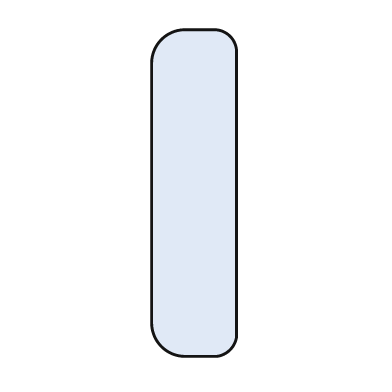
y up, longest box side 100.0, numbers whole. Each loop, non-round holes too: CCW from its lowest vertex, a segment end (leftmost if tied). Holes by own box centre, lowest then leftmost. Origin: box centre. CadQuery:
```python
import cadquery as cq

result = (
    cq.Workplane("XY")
    .moveTo(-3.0, -50.0)
    .lineTo(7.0, -50.0)
    .threePointArc((11.0, -48.0), (13.0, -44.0))
    .lineTo(13.0, 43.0)
    .threePointArc((11.0, 48.0), (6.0, 50.0))
    .lineTo(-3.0, 50.0)
    .threePointArc((-10.0, 47.0), (-13.0, 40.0))
    .lineTo(-13.0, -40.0)
    .threePointArc((-10.0, -47.0), (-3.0, -50.0))
    .close()
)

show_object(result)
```